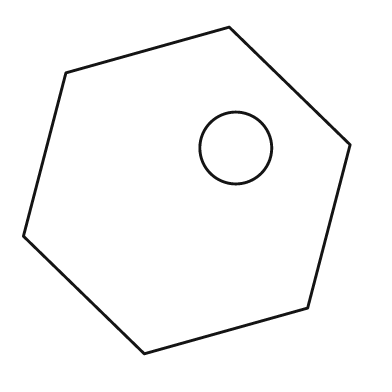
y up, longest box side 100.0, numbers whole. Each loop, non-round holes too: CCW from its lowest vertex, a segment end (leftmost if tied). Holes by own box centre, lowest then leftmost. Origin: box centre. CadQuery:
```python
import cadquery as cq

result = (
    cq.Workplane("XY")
    .moveTo(-13.0, -50.0)
    .lineTo(37.0, -36.0)
    .lineTo(50.0, 14.0)
    .lineTo(13.0, 50.0)
    .lineTo(-37.0, 36.0)
    .lineTo(-50.0, -14.0)
    .close()
    .moveTo(15.0, 13.0)
    .circle(11.0)
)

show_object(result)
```